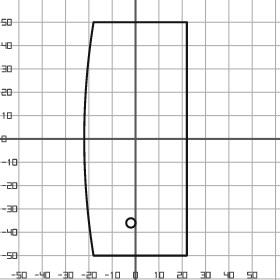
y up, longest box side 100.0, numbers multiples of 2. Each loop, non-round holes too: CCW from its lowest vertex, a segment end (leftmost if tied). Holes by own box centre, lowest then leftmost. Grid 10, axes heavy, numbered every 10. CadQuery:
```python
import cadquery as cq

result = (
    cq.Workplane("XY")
    .moveTo(-18.0, -50.0)
    .lineTo(22.0, -50.0)
    .lineTo(22.0, 50.0)
    .lineTo(-18.0, 50.0)
    .threePointArc((-22.0, 0.0), (-18.0, -50.0))
    .close()
    .moveTo(-2.0, -36.0)
    .circle(2.0)
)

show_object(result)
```